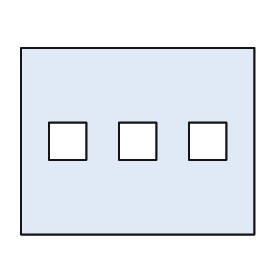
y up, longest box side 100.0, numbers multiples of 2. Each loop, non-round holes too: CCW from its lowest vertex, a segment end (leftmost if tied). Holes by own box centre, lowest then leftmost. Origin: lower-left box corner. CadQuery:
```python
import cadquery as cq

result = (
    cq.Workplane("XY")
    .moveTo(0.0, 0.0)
    .lineTo(100.0, 0.0)
    .lineTo(100.0, 80.0)
    .lineTo(0.0, 80.0)
    .close()
    .moveTo(12.0, 32.0)
    .lineTo(28.0, 32.0)
    .lineTo(28.0, 48.0)
    .lineTo(12.0, 48.0)
    .close()
    .moveTo(42.0, 32.0)
    .lineTo(58.0, 32.0)
    .lineTo(58.0, 48.0)
    .lineTo(42.0, 48.0)
    .close()
    .moveTo(72.0, 32.0)
    .lineTo(88.0, 32.0)
    .lineTo(88.0, 48.0)
    .lineTo(72.0, 48.0)
    .close()
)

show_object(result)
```